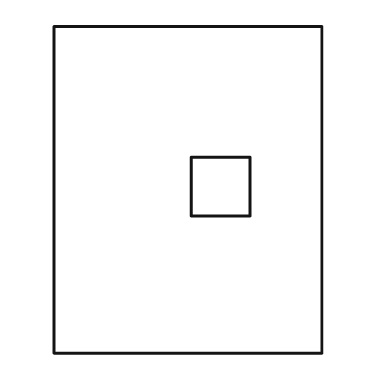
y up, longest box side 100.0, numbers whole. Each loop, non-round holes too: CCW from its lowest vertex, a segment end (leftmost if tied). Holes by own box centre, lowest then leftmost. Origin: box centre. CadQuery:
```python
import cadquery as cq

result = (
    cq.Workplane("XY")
    .moveTo(-41.0, -50.0)
    .lineTo(41.0, -50.0)
    .lineTo(41.0, 50.0)
    .lineTo(-41.0, 50.0)
    .close()
    .moveTo(1.0, -8.0)
    .lineTo(19.0, -8.0)
    .lineTo(19.0, 10.0)
    .lineTo(1.0, 10.0)
    .close()
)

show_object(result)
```